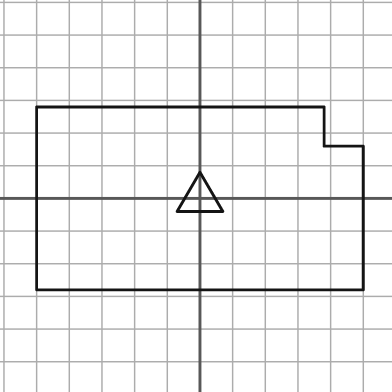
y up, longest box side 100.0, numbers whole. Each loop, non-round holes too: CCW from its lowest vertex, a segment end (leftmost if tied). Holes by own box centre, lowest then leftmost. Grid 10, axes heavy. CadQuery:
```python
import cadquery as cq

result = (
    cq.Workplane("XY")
    .moveTo(-50.0, -28.0)
    .lineTo(50.0, -28.0)
    .lineTo(50.0, 16.0)
    .lineTo(38.0, 16.0)
    .lineTo(38.0, 28.0)
    .lineTo(-50.0, 28.0)
    .close()
    .moveTo(-7.0, -4.0)
    .lineTo(7.0, -4.0)
    .lineTo(0.0, 8.0)
    .close()
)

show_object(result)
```